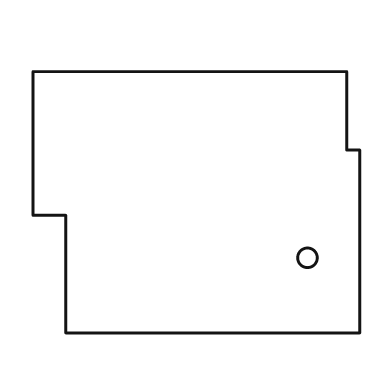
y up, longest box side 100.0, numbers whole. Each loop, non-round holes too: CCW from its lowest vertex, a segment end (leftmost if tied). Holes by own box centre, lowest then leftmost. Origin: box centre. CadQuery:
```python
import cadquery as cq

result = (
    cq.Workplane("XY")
    .moveTo(-40.0, -40.0)
    .lineTo(50.0, -40.0)
    .lineTo(50.0, 16.0)
    .lineTo(46.0, 16.0)
    .lineTo(46.0, 40.0)
    .lineTo(-50.0, 40.0)
    .lineTo(-50.0, -4.0)
    .lineTo(-40.0, -4.0)
    .close()
    .moveTo(34.0, -17.0)
    .circle(3.0)
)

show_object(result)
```